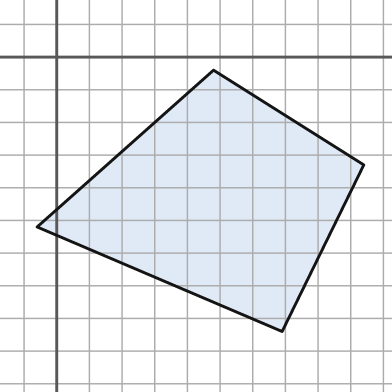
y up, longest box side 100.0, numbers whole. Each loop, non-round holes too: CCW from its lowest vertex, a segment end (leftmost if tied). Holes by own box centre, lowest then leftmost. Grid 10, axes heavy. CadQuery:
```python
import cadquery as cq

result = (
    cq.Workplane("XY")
    .moveTo(69.0, -84.0)
    .lineTo(94.0, -33.0)
    .lineTo(48.0, -4.0)
    .lineTo(-6.0, -52.0)
    .close()
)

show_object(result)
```